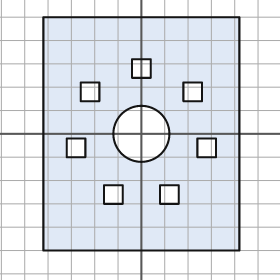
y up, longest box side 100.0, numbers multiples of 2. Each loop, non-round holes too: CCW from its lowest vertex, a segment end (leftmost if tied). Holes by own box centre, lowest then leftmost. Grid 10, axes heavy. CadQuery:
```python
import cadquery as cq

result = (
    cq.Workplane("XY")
    .moveTo(-42.0, -50.0)
    .lineTo(42.0, -50.0)
    .lineTo(42.0, 50.0)
    .lineTo(-42.0, 50.0)
    .close()
    .moveTo(-16.0, -30.0)
    .lineTo(-8.0, -30.0)
    .lineTo(-8.0, -22.0)
    .lineTo(-16.0, -22.0)
    .close()
    .moveTo(8.0, -30.0)
    .lineTo(16.0, -30.0)
    .lineTo(16.0, -22.0)
    .lineTo(8.0, -22.0)
    .close()
    .moveTo(-32.0, -10.0)
    .lineTo(-24.0, -10.0)
    .lineTo(-24.0, -2.0)
    .lineTo(-32.0, -2.0)
    .close()
    .moveTo(24.0, -10.0)
    .lineTo(32.0, -10.0)
    .lineTo(32.0, -2.0)
    .lineTo(24.0, -2.0)
    .close()
    .moveTo(0.0, 0.0)
    .circle(12.0)
    .moveTo(-26.0, 14.0)
    .lineTo(-18.0, 14.0)
    .lineTo(-18.0, 22.0)
    .lineTo(-26.0, 22.0)
    .close()
    .moveTo(18.0, 14.0)
    .lineTo(26.0, 14.0)
    .lineTo(26.0, 22.0)
    .lineTo(18.0, 22.0)
    .close()
    .moveTo(-4.0, 24.0)
    .lineTo(4.0, 24.0)
    .lineTo(4.0, 32.0)
    .lineTo(-4.0, 32.0)
    .close()
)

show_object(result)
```